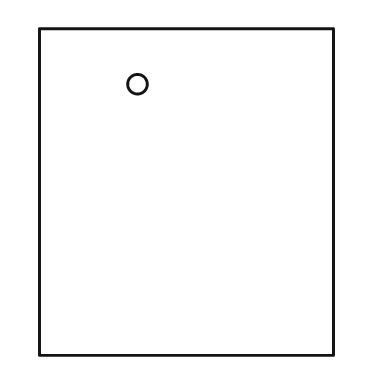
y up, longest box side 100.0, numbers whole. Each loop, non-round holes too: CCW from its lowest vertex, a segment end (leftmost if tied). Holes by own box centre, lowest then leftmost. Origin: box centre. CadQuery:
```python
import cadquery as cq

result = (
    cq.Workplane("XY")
    .moveTo(-45.0, -50.0)
    .lineTo(45.0, -50.0)
    .lineTo(45.0, 50.0)
    .lineTo(-45.0, 50.0)
    .close()
    .moveTo(-15.0, 33.0)
    .circle(3.0)
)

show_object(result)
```